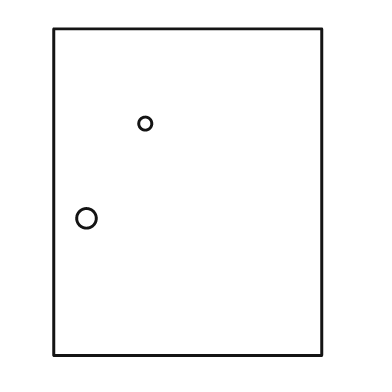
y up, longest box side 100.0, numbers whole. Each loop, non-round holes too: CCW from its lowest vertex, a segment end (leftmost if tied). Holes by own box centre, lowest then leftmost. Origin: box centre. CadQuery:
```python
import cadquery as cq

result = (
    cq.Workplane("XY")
    .moveTo(-41.0, -50.0)
    .lineTo(41.0, -50.0)
    .lineTo(41.0, 50.0)
    .lineTo(-41.0, 50.0)
    .close()
    .moveTo(-31.0, -8.0)
    .circle(3.0)
    .moveTo(-13.0, 21.0)
    .circle(2.0)
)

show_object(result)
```